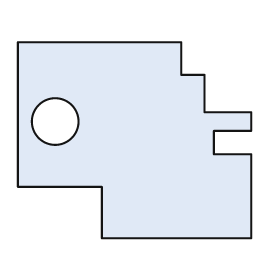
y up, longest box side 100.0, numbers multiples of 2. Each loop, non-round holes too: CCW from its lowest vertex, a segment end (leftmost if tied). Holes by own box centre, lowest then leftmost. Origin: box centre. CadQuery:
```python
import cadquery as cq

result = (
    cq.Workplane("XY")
    .moveTo(-14.0, -42.0)
    .lineTo(50.0, -42.0)
    .lineTo(50.0, -6.0)
    .lineTo(34.0, -6.0)
    .lineTo(34.0, 4.0)
    .lineTo(50.0, 4.0)
    .lineTo(50.0, 12.0)
    .lineTo(30.0, 12.0)
    .lineTo(30.0, 28.0)
    .lineTo(20.0, 28.0)
    .lineTo(20.0, 42.0)
    .lineTo(-50.0, 42.0)
    .lineTo(-50.0, -20.0)
    .lineTo(-14.0, -20.0)
    .close()
    .moveTo(-34.0, 8.0)
    .circle(10.0)
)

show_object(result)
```